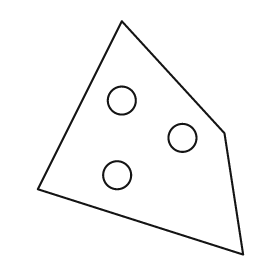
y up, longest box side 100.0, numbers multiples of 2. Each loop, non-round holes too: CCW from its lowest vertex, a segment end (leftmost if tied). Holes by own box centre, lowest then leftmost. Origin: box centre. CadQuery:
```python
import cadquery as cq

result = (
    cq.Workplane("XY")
    .moveTo(44.0, -50.0)
    .lineTo(36.0, 2.0)
    .lineTo(-8.0, 50.0)
    .lineTo(-44.0, -22.0)
    .close()
    .moveTo(-10.0, -16.0)
    .circle(6.0)
    .moveTo(18.0, 0.0)
    .circle(6.0)
    .moveTo(-8.0, 16.0)
    .circle(6.0)
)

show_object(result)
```